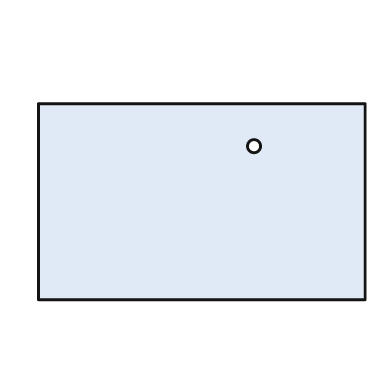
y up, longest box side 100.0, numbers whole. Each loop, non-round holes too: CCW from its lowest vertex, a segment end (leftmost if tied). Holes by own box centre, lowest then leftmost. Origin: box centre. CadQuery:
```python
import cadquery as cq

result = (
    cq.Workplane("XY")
    .moveTo(-50.0, -30.0)
    .lineTo(50.0, -30.0)
    .lineTo(50.0, 30.0)
    .lineTo(-50.0, 30.0)
    .close()
    .moveTo(16.0, 17.0)
    .circle(2.0)
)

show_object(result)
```